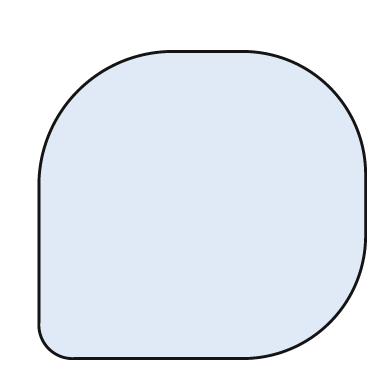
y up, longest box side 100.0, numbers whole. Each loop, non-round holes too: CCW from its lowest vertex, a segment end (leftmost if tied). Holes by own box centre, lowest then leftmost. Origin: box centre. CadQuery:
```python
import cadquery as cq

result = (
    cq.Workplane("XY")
    .moveTo(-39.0, -47.0)
    .lineTo(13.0, -47.0)
    .threePointArc((39.0, -36.0), (50.0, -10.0))
    .lineTo(50.0, 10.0)
    .threePointArc((39.0, 36.0), (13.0, 47.0))
    .lineTo(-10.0, 47.0)
    .threePointArc((-38.0, 35.0), (-50.0, 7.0))
    .lineTo(-50.0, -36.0)
    .threePointArc((-47.0, -44.0), (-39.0, -47.0))
    .close()
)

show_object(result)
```